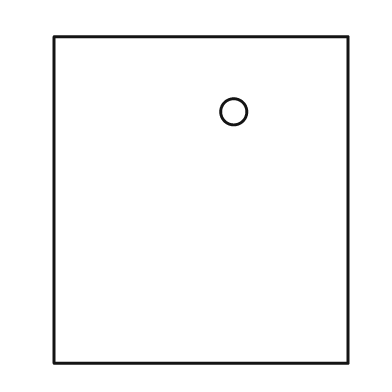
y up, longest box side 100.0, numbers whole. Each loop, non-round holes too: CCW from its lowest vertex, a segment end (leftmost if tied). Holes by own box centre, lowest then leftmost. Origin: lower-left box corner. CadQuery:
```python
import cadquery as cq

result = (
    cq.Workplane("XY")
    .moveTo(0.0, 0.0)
    .lineTo(90.0, 0.0)
    .lineTo(90.0, 100.0)
    .lineTo(0.0, 100.0)
    .close()
    .moveTo(55.0, 77.0)
    .circle(4.0)
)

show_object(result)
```